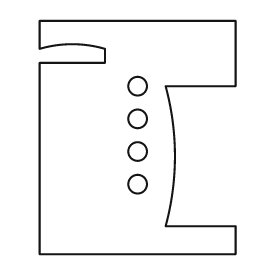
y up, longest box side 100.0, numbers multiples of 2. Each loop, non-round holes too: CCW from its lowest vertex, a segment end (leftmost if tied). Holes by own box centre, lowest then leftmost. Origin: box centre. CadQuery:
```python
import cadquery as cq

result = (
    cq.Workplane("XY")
    .moveTo(-42.0, -50.0)
    .lineTo(42.0, -50.0)
    .lineTo(42.0, -38.0)
    .lineTo(12.0, -38.0)
    .threePointArc((16.0, -8.0), (12.0, 22.0))
    .lineTo(42.0, 22.0)
    .lineTo(42.0, 50.0)
    .lineTo(-42.0, 50.0)
    .lineTo(-42.0, 38.0)
    .threePointArc((-28.0, 40.0), (-14.0, 38.0))
    .lineTo(-14.0, 32.0)
    .lineTo(-42.0, 32.0)
    .close()
    .moveTo(0.0, -20.0)
    .circle(4.0)
    .moveTo(0.0, -6.0)
    .circle(4.0)
    .moveTo(0.0, 8.0)
    .circle(4.0)
    .moveTo(0.0, 22.0)
    .circle(4.0)
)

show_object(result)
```